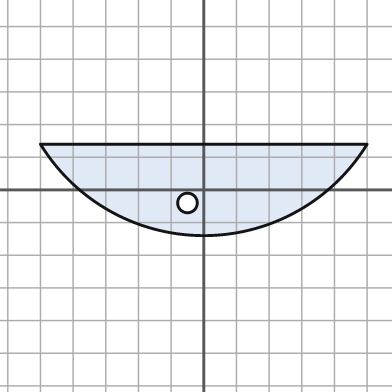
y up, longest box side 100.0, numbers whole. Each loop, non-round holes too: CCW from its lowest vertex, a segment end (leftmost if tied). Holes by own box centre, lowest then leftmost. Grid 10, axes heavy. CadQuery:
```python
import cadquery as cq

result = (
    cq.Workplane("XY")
    .moveTo(-50.0, 14.0)
    .threePointArc((0.0, -14.0), (50.0, 14.0))
    .close()
    .moveTo(-5.0, -4.0)
    .circle(3.0)
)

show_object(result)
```